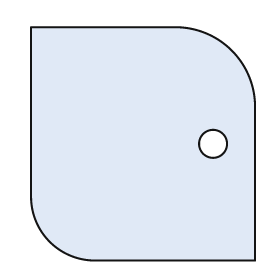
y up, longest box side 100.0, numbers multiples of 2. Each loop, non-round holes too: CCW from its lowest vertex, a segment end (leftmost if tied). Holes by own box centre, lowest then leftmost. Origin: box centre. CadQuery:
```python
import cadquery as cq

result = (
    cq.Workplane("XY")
    .moveTo(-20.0, -50.0)
    .lineTo(48.0, -50.0)
    .lineTo(48.0, 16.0)
    .threePointArc((38.0, 40.0), (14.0, 50.0))
    .lineTo(-48.0, 50.0)
    .lineTo(-48.0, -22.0)
    .threePointArc((-40.0, -42.0), (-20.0, -50.0))
    .close()
    .moveTo(30.0, 0.0)
    .circle(6.0)
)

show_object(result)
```